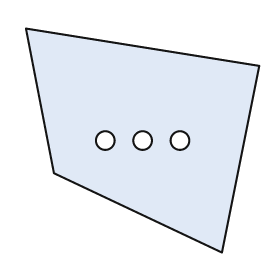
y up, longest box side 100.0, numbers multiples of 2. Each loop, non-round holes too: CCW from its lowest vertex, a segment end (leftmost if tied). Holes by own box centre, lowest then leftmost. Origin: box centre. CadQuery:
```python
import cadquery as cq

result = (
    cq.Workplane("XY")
    .moveTo(34.0, -48.0)
    .lineTo(50.0, 32.0)
    .lineTo(-50.0, 48.0)
    .lineTo(-38.0, -14.0)
    .close()
    .moveTo(-16.0, 0.0)
    .circle(4.0)
    .moveTo(0.0, 0.0)
    .circle(4.0)
    .moveTo(16.0, 0.0)
    .circle(4.0)
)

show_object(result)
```